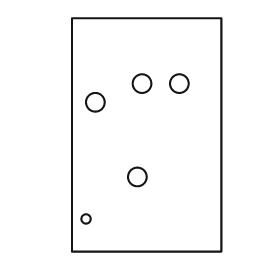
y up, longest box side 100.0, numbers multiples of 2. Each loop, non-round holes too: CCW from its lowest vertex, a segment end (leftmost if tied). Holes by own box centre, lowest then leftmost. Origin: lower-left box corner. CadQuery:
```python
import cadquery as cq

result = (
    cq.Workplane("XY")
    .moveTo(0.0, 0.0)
    .lineTo(64.0, 0.0)
    .lineTo(64.0, 100.0)
    .lineTo(0.0, 100.0)
    .close()
    .moveTo(6.0, 14.0)
    .circle(2.0)
    .moveTo(28.0, 32.0)
    .circle(4.0)
    .moveTo(10.0, 64.0)
    .circle(4.0)
    .moveTo(30.0, 72.0)
    .circle(4.0)
    .moveTo(46.0, 72.0)
    .circle(4.0)
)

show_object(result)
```